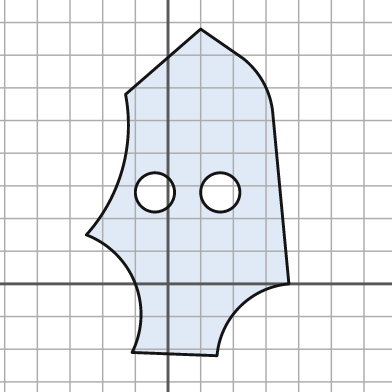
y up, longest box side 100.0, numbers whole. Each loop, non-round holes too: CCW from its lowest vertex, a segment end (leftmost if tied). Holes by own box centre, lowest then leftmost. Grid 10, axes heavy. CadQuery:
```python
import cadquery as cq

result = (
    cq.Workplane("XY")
    .moveTo(15.0, -22.0)
    .threePointArc((22.0, -7.0), (37.0, 0.0))
    .lineTo(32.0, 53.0)
    .threePointArc((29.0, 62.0), (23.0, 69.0))
    .lineTo(10.0, 78.0)
    .lineTo(-13.0, 58.0)
    .threePointArc((-14.0, 35.0), (-25.0, 15.0))
    .threePointArc((-10.0, 0.0), (-11.0, -21.0))
    .close()
    .moveTo(-4.0, 28.0)
    .circle(6.0)
    .moveTo(16.0, 28.0)
    .circle(6.0)
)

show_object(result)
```